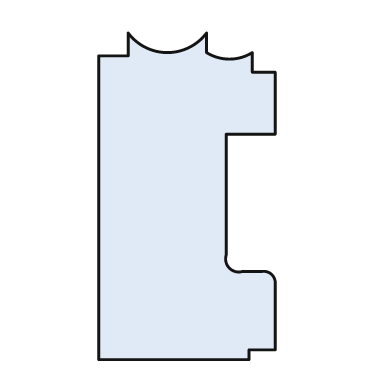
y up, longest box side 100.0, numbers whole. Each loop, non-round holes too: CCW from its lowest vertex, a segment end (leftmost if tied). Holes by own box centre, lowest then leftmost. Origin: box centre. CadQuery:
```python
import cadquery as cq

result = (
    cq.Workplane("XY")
    .moveTo(-27.0, -50.0)
    .lineTo(19.0, -50.0)
    .lineTo(19.0, -47.0)
    .lineTo(27.0, -47.0)
    .lineTo(27.0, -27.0)
    .threePointArc((26.0, -24.0), (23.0, -23.0))
    .lineTo(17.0, -23.0)
    .threePointArc((13.0, -22.0), (12.0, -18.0))
    .lineTo(12.0, 19.0)
    .lineTo(27.0, 19.0)
    .lineTo(27.0, 38.0)
    .lineTo(20.0, 38.0)
    .lineTo(20.0, 44.0)
    .threePointArc((13.0, 42.0), (6.0, 44.0))
    .lineTo(6.0, 50.0)
    .threePointArc((-6.0, 44.0), (-18.0, 50.0))
    .lineTo(-18.0, 43.0)
    .lineTo(-27.0, 43.0)
    .close()
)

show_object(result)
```